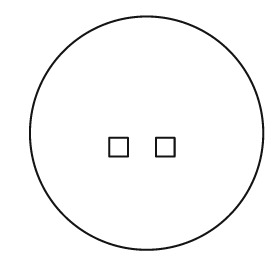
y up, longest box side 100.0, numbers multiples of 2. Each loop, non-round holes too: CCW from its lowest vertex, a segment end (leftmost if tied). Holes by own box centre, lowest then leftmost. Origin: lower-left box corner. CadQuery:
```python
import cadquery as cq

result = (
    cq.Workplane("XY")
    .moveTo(50.0, 50.0)
    .circle(50.0)
    .moveTo(34.0, 40.0)
    .lineTo(42.0, 40.0)
    .lineTo(42.0, 48.0)
    .lineTo(34.0, 48.0)
    .close()
    .moveTo(54.0, 40.0)
    .lineTo(62.0, 40.0)
    .lineTo(62.0, 48.0)
    .lineTo(54.0, 48.0)
    .close()
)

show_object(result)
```